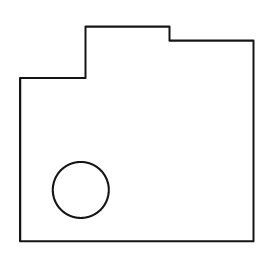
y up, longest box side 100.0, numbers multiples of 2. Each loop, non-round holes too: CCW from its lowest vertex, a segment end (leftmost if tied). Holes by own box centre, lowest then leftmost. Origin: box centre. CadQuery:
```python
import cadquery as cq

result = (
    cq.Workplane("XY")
    .moveTo(-50.0, -46.0)
    .lineTo(50.0, -46.0)
    .lineTo(50.0, 40.0)
    .lineTo(14.0, 40.0)
    .lineTo(14.0, 46.0)
    .lineTo(-22.0, 46.0)
    .lineTo(-22.0, 24.0)
    .lineTo(-50.0, 24.0)
    .close()
    .moveTo(-24.0, -24.0)
    .circle(12.0)
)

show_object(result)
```